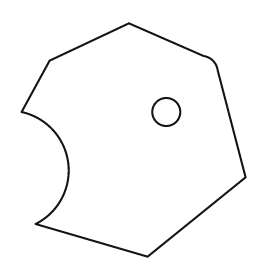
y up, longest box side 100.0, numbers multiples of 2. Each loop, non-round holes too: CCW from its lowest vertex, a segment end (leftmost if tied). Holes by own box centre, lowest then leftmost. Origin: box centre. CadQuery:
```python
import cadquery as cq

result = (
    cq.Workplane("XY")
    .moveTo(6.0, -50.0)
    .lineTo(48.0, -16.0)
    .lineTo(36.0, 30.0)
    .threePointArc((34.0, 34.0), (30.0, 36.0))
    .lineTo(-2.0, 50.0)
    .lineTo(-36.0, 34.0)
    .lineTo(-48.0, 12.0)
    .threePointArc((-28.0, -10.0), (-42.0, -36.0))
    .close()
    .moveTo(14.0, 12.0)
    .circle(6.0)
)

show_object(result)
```